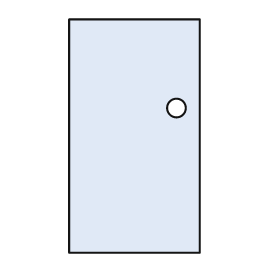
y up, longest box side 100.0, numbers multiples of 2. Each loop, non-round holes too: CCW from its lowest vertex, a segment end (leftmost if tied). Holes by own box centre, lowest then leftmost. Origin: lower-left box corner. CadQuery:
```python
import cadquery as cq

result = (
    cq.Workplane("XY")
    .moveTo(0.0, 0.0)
    .lineTo(56.0, 0.0)
    .lineTo(56.0, 100.0)
    .lineTo(0.0, 100.0)
    .close()
    .moveTo(46.0, 62.0)
    .circle(4.0)
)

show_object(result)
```